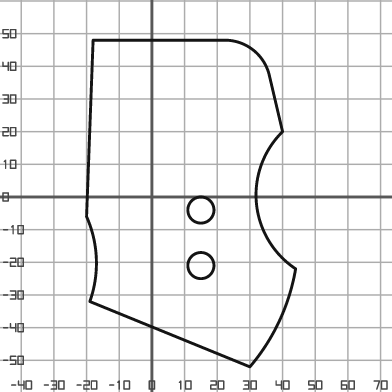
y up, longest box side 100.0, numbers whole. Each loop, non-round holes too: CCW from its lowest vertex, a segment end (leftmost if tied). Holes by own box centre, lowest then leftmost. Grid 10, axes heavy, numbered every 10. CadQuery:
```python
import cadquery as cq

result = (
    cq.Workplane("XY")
    .moveTo(30.0, -52.0)
    .threePointArc((39.0, -38.0), (44.0, -22.0))
    .threePointArc((32.0, -2.0), (40.0, 20.0))
    .lineTo(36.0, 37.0)
    .threePointArc((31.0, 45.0), (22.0, 48.0))
    .lineTo(-18.0, 48.0)
    .lineTo(-20.0, -6.0)
    .threePointArc((-17.0, -19.0), (-19.0, -32.0))
    .close()
    .moveTo(15.0, -21.0)
    .circle(4.0)
    .moveTo(15.0, -4.0)
    .circle(4.0)
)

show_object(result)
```